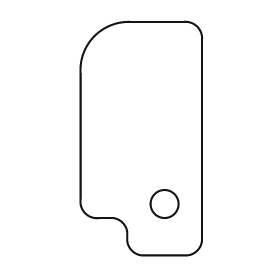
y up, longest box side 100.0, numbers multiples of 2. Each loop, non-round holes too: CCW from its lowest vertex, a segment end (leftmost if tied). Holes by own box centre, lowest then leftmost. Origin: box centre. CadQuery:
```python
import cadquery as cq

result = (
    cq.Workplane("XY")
    .moveTo(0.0, -50.0)
    .lineTo(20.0, -50.0)
    .threePointArc((24.0, -48.0), (26.0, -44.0))
    .lineTo(26.0, 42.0)
    .threePointArc((24.0, 48.0), (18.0, 50.0))
    .lineTo(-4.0, 50.0)
    .threePointArc((-20.0, 44.0), (-26.0, 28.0))
    .lineTo(-26.0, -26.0)
    .threePointArc((-24.0, -32.0), (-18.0, -34.0))
    .lineTo(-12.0, -34.0)
    .threePointArc((-8.0, -36.0), (-6.0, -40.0))
    .lineTo(-6.0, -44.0)
    .threePointArc((-4.0, -48.0), (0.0, -50.0))
    .close()
    .moveTo(10.0, -28.0)
    .circle(6.0)
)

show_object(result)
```